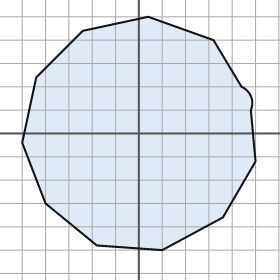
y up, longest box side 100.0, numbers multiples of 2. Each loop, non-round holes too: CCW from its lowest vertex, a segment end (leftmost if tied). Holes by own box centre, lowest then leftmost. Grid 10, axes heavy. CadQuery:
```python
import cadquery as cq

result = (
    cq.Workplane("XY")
    .moveTo(10.0, -50.0)
    .lineTo(36.0, -36.0)
    .lineTo(50.0, -12.0)
    .lineTo(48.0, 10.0)
    .threePointArc((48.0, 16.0), (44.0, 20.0))
    .lineTo(32.0, 40.0)
    .lineTo(4.0, 50.0)
    .lineTo(-24.0, 44.0)
    .lineTo(-44.0, 24.0)
    .lineTo(-50.0, -4.0)
    .lineTo(-40.0, -30.0)
    .lineTo(-18.0, -48.0)
    .close()
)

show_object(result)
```